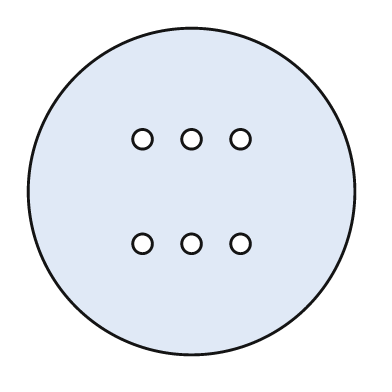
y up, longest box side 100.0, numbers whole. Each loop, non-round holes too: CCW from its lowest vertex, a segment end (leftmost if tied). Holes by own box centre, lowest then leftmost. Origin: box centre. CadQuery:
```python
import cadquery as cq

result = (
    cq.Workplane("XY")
    .moveTo(0.0, 0.0)
    .circle(50.0)
    .moveTo(-15.0, -16.0)
    .circle(3.0)
    .moveTo(0.0, -16.0)
    .circle(3.0)
    .moveTo(15.0, -16.0)
    .circle(3.0)
    .moveTo(-15.0, 16.0)
    .circle(3.0)
    .moveTo(0.0, 16.0)
    .circle(3.0)
    .moveTo(15.0, 16.0)
    .circle(3.0)
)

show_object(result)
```